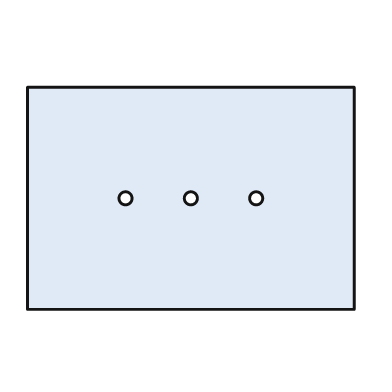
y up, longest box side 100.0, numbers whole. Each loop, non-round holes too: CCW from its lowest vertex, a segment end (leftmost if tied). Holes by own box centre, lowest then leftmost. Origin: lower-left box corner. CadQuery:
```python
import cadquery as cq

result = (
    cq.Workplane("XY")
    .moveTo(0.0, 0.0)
    .lineTo(100.0, 0.0)
    .lineTo(100.0, 68.0)
    .lineTo(0.0, 68.0)
    .close()
    .moveTo(30.0, 34.0)
    .circle(2.0)
    .moveTo(50.0, 34.0)
    .circle(2.0)
    .moveTo(70.0, 34.0)
    .circle(2.0)
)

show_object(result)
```